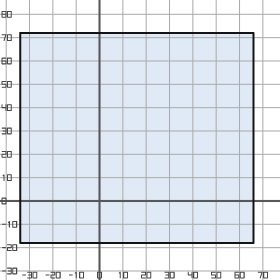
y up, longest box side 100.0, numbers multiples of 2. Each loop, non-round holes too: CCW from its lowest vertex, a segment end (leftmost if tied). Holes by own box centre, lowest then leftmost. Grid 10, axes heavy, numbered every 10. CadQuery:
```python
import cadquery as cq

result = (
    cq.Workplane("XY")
    .moveTo(-34.0, -18.0)
    .lineTo(66.0, -18.0)
    .lineTo(66.0, 72.0)
    .lineTo(-34.0, 72.0)
    .close()
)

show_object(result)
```